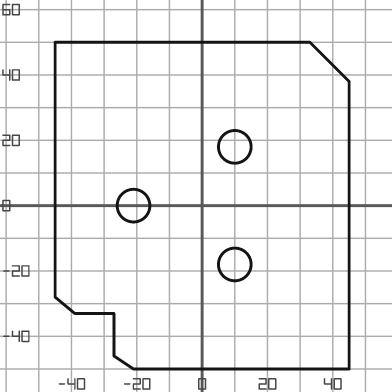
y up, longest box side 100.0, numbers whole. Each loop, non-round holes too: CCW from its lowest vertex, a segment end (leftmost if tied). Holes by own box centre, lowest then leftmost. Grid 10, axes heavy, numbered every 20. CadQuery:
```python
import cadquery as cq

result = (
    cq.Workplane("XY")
    .moveTo(-21.0, -50.0)
    .lineTo(45.0, -50.0)
    .lineTo(45.0, 38.0)
    .lineTo(33.0, 50.0)
    .lineTo(-45.0, 50.0)
    .lineTo(-45.0, -28.0)
    .lineTo(-39.0, -33.0)
    .lineTo(-27.0, -33.0)
    .lineTo(-27.0, -46.0)
    .close()
    .moveTo(10.0, -18.0)
    .circle(5.0)
    .moveTo(-21.0, 0.0)
    .circle(5.0)
    .moveTo(10.0, 18.0)
    .circle(5.0)
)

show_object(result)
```